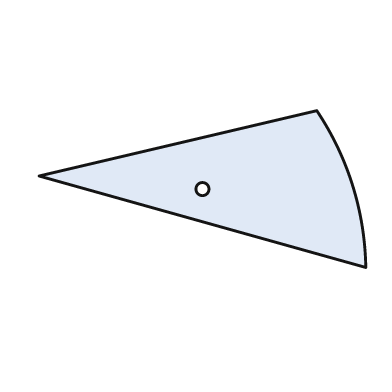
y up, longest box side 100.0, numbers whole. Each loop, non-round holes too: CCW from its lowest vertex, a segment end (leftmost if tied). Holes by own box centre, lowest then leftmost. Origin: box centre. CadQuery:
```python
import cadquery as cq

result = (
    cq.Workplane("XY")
    .moveTo(50.0, -24.0)
    .threePointArc((46.0, 1.0), (35.0, 24.0))
    .lineTo(-50.0, 4.0)
    .close()
    .moveTo(0.0, 0.0)
    .circle(2.0)
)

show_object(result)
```